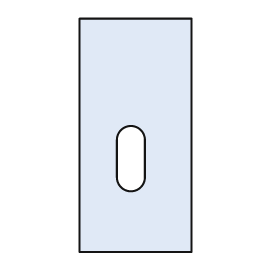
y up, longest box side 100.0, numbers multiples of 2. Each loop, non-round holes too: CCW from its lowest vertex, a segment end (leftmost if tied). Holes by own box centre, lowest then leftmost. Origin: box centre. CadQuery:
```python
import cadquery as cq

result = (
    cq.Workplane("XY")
    .moveTo(-24.0, -50.0)
    .lineTo(24.0, -50.0)
    .lineTo(24.0, 50.0)
    .lineTo(-24.0, 50.0)
    .close()
    .moveTo(-8.0, -18.0)
    .threePointArc((-2.0, -24.0), (4.0, -18.0))
    .lineTo(4.0, -2.0)
    .threePointArc((-2.0, 4.0), (-8.0, -2.0))
    .close()
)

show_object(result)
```